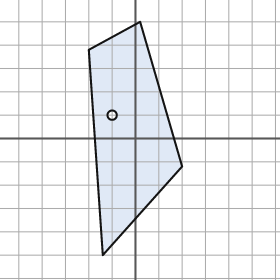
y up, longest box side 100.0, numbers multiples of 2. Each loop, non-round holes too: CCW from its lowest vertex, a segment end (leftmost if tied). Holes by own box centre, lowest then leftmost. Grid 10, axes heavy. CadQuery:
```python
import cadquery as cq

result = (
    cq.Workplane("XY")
    .moveTo(-14.0, -50.0)
    .lineTo(20.0, -12.0)
    .lineTo(2.0, 50.0)
    .lineTo(-20.0, 38.0)
    .close()
    .moveTo(-10.0, 10.0)
    .circle(2.0)
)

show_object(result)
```